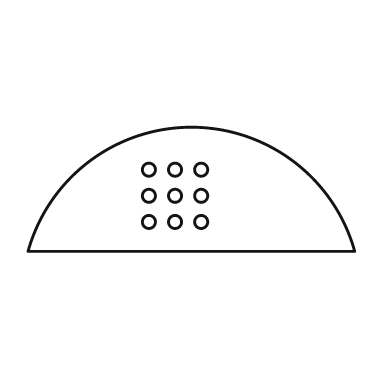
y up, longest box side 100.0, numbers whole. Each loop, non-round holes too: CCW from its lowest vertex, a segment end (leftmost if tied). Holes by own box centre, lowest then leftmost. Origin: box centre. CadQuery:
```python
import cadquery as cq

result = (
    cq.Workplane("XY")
    .moveTo(-50.0, -19.0)
    .lineTo(50.0, -19.0)
    .threePointArc((0.0, 19.0), (-50.0, -19.0))
    .close()
    .moveTo(-13.0, -10.0)
    .circle(2.0)
    .moveTo(-5.0, -10.0)
    .circle(2.0)
    .moveTo(3.0, -10.0)
    .circle(2.0)
    .moveTo(-13.0, -2.0)
    .circle(2.0)
    .moveTo(-5.0, -2.0)
    .circle(2.0)
    .moveTo(3.0, -2.0)
    .circle(2.0)
    .moveTo(-13.0, 6.0)
    .circle(2.0)
    .moveTo(-5.0, 6.0)
    .circle(2.0)
    .moveTo(3.0, 6.0)
    .circle(2.0)
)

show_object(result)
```